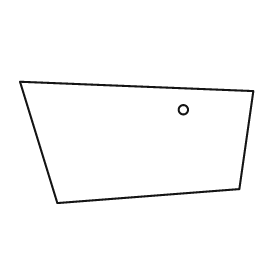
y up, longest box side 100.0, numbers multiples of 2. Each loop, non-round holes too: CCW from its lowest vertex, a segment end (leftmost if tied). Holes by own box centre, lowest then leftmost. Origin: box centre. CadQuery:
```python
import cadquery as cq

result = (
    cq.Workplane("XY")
    .moveTo(-34.0, -26.0)
    .lineTo(44.0, -20.0)
    .lineTo(50.0, 22.0)
    .lineTo(-50.0, 26.0)
    .close()
    .moveTo(20.0, 14.0)
    .circle(2.0)
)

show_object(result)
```